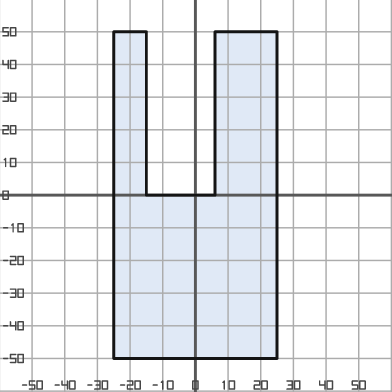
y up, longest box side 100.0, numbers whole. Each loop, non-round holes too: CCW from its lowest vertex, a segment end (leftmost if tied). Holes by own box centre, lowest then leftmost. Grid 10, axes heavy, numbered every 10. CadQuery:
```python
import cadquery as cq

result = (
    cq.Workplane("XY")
    .moveTo(-25.0, -50.0)
    .lineTo(25.0, -50.0)
    .lineTo(25.0, 50.0)
    .lineTo(6.0, 50.0)
    .lineTo(6.0, 0.0)
    .lineTo(-15.0, 0.0)
    .lineTo(-15.0, 50.0)
    .lineTo(-25.0, 50.0)
    .close()
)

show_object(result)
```